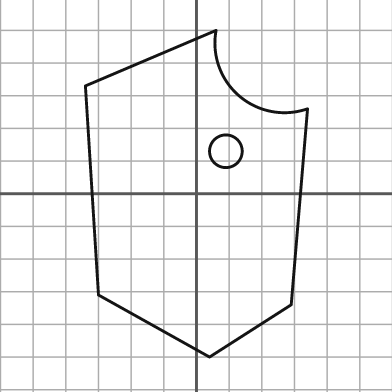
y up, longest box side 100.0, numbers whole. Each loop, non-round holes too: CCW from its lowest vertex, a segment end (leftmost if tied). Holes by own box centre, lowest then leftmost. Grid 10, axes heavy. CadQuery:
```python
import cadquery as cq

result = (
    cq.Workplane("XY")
    .moveTo(4.0, -50.0)
    .lineTo(29.0, -34.0)
    .lineTo(34.0, 26.0)
    .threePointArc((13.0, 30.0), (6.0, 50.0))
    .lineTo(-34.0, 33.0)
    .lineTo(-30.0, -31.0)
    .close()
    .moveTo(9.0, 13.0)
    .circle(5.0)
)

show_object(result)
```